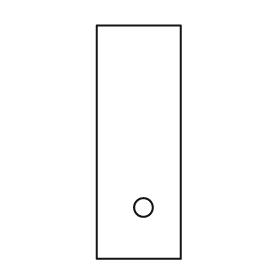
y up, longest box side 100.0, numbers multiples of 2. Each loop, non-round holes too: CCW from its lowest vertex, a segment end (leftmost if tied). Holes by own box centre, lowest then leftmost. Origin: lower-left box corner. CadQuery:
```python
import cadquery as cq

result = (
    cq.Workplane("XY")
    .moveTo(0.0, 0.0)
    .lineTo(36.0, 0.0)
    .lineTo(36.0, 100.0)
    .lineTo(0.0, 100.0)
    .close()
    .moveTo(20.0, 22.0)
    .circle(4.0)
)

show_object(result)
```